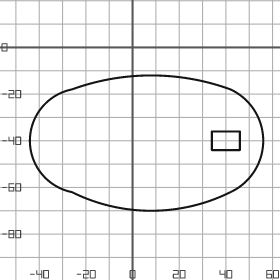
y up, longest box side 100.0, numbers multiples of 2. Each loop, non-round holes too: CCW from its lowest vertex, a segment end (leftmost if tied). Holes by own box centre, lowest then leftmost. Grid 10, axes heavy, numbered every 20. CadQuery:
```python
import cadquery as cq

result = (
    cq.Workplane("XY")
    .moveTo(-26.0, -62.0)
    .threePointArc((8.0, -70.0), (42.0, -62.0))
    .threePointArc((56.0, -40.0), (42.0, -18.0))
    .threePointArc((8.0, -12.0), (-26.0, -18.0))
    .threePointArc((-44.0, -40.0), (-26.0, -62.0))
    .close()
    .moveTo(34.0, -44.0)
    .lineTo(46.0, -44.0)
    .lineTo(46.0, -36.0)
    .lineTo(34.0, -36.0)
    .close()
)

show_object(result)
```